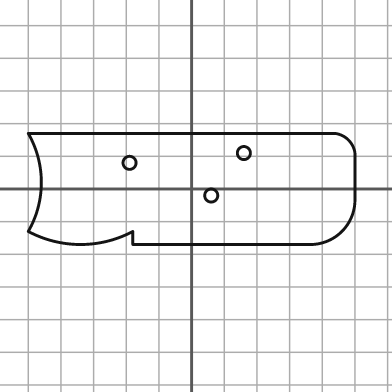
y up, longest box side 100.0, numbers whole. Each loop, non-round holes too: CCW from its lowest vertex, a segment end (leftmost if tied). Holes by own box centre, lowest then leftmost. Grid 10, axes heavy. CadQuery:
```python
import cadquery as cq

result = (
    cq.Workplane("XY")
    .moveTo(-18.0, -17.0)
    .lineTo(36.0, -17.0)
    .threePointArc((46.0, -13.0), (50.0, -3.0))
    .lineTo(50.0, 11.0)
    .threePointArc((48.0, 15.0), (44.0, 17.0))
    .lineTo(-50.0, 17.0)
    .threePointArc((-46.0, 2.0), (-50.0, -13.0))
    .threePointArc((-34.0, -17.0), (-18.0, -13.0))
    .close()
    .moveTo(6.0, -2.0)
    .circle(2.0)
    .moveTo(-19.0, 8.0)
    .circle(2.0)
    .moveTo(16.0, 11.0)
    .circle(2.0)
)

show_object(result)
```